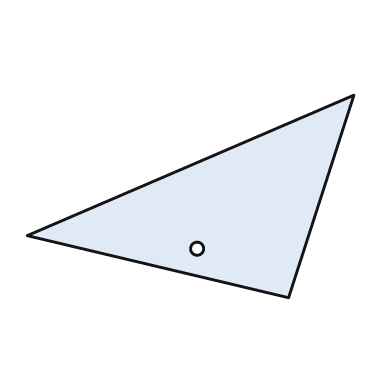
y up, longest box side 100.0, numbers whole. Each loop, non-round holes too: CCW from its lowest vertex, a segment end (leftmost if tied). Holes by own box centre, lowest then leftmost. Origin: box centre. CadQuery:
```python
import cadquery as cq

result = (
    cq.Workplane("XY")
    .moveTo(30.0, -31.0)
    .lineTo(50.0, 31.0)
    .lineTo(-50.0, -12.0)
    .close()
    .moveTo(2.0, -16.0)
    .circle(2.0)
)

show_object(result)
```